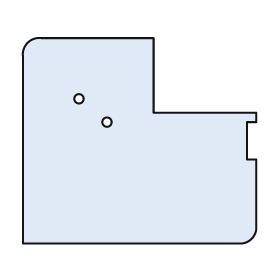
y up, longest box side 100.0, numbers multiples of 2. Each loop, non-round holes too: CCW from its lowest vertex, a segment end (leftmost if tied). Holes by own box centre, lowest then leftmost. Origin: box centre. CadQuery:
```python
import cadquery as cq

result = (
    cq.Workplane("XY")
    .moveTo(-50.0, -44.0)
    .lineTo(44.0, -44.0)
    .threePointArc((48.0, -42.0), (50.0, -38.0))
    .lineTo(50.0, -8.0)
    .lineTo(46.0, -8.0)
    .lineTo(46.0, 8.0)
    .lineTo(50.0, 8.0)
    .lineTo(50.0, 12.0)
    .lineTo(6.0, 12.0)
    .lineTo(6.0, 44.0)
    .lineTo(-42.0, 44.0)
    .threePointArc((-48.0, 42.0), (-50.0, 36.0))
    .close()
    .moveTo(-14.0, 8.0)
    .circle(2.0)
    .moveTo(-26.0, 18.0)
    .circle(2.0)
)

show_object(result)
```